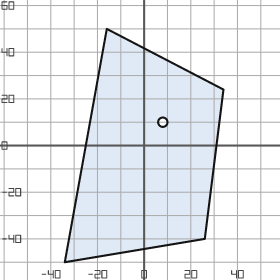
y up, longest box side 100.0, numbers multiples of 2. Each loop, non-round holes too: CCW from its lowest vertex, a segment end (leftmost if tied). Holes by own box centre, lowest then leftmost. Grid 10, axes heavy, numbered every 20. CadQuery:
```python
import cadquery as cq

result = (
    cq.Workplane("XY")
    .moveTo(-34.0, -50.0)
    .lineTo(26.0, -40.0)
    .lineTo(34.0, 24.0)
    .lineTo(-16.0, 50.0)
    .close()
    .moveTo(8.0, 10.0)
    .circle(2.0)
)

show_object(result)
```